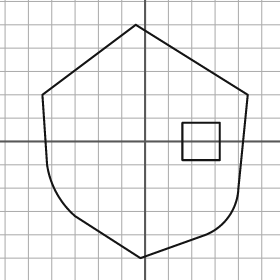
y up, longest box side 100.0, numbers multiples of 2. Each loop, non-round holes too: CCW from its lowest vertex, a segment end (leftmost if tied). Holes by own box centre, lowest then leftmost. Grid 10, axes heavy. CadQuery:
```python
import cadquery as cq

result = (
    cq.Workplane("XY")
    .moveTo(-2.0, -50.0)
    .lineTo(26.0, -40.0)
    .threePointArc((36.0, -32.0), (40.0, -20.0))
    .lineTo(44.0, 20.0)
    .lineTo(-4.0, 50.0)
    .lineTo(-44.0, 20.0)
    .lineTo(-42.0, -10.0)
    .threePointArc((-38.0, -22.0), (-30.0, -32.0))
    .close()
    .moveTo(16.0, -8.0)
    .lineTo(32.0, -8.0)
    .lineTo(32.0, 8.0)
    .lineTo(16.0, 8.0)
    .close()
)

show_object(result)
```